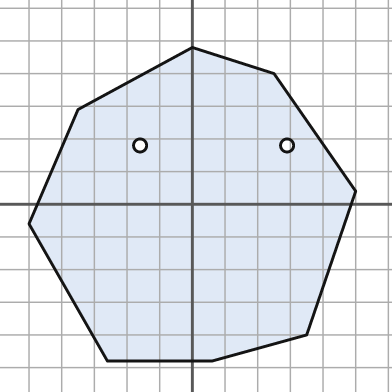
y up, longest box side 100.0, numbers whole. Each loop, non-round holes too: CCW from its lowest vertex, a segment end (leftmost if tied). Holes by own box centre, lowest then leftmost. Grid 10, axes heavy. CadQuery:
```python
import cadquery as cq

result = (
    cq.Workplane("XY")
    .moveTo(-26.0, -48.0)
    .lineTo(6.0, -48.0)
    .lineTo(35.0, -40.0)
    .lineTo(50.0, 4.0)
    .lineTo(25.0, 40.0)
    .lineTo(0.0, 48.0)
    .lineTo(-35.0, 29.0)
    .lineTo(-50.0, -6.0)
    .close()
    .moveTo(-16.0, 18.0)
    .circle(2.0)
    .moveTo(29.0, 18.0)
    .circle(2.0)
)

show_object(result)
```